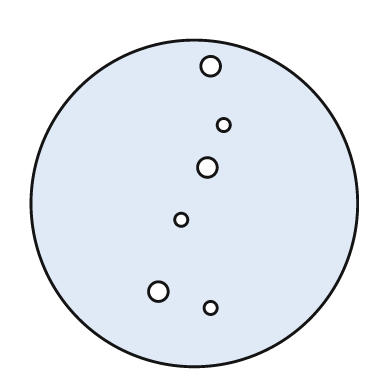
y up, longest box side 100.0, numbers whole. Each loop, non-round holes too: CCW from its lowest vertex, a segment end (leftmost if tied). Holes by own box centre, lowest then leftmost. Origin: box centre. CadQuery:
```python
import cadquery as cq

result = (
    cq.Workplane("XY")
    .moveTo(0.0, 0.0)
    .circle(50.0)
    .moveTo(5.0, -32.0)
    .circle(2.0)
    .moveTo(-11.0, -27.0)
    .circle(3.0)
    .moveTo(-4.0, -5.0)
    .circle(2.0)
    .moveTo(4.0, 11.0)
    .circle(3.0)
    .moveTo(9.0, 24.0)
    .circle(2.0)
    .moveTo(5.0, 42.0)
    .circle(3.0)
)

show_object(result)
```